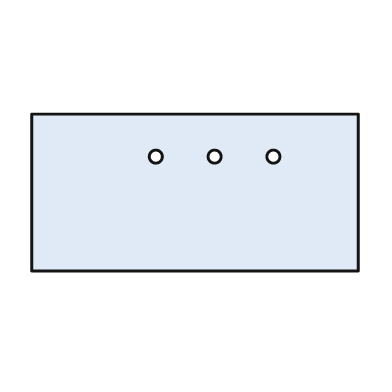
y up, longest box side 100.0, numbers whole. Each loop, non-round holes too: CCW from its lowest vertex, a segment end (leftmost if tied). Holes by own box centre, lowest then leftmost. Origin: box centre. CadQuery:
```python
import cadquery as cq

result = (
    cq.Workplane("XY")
    .moveTo(-50.0, -24.0)
    .lineTo(50.0, -24.0)
    .lineTo(50.0, 24.0)
    .lineTo(-50.0, 24.0)
    .close()
    .moveTo(-12.0, 11.0)
    .circle(2.0)
    .moveTo(6.0, 11.0)
    .circle(2.0)
    .moveTo(24.0, 11.0)
    .circle(2.0)
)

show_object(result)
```